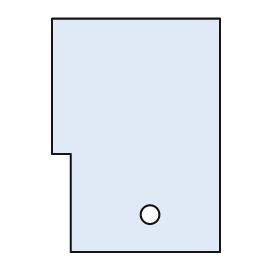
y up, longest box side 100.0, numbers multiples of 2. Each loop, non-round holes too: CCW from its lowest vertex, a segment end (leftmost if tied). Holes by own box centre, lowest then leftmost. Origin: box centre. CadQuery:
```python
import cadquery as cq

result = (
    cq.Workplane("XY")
    .moveTo(-28.0, -50.0)
    .lineTo(36.0, -50.0)
    .lineTo(36.0, 50.0)
    .lineTo(-36.0, 50.0)
    .lineTo(-36.0, -8.0)
    .lineTo(-28.0, -8.0)
    .close()
    .moveTo(6.0, -34.0)
    .circle(4.0)
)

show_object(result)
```